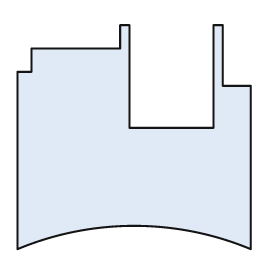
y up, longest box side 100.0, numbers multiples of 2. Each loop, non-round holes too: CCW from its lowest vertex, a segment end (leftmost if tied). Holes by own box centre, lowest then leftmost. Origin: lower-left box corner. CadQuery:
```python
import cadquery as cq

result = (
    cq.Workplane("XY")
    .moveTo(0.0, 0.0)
    .threePointArc((50.0, 10.0), (100.0, 0.0))
    .lineTo(100.0, 70.0)
    .lineTo(88.0, 70.0)
    .lineTo(88.0, 96.0)
    .lineTo(84.0, 96.0)
    .lineTo(84.0, 52.0)
    .lineTo(48.0, 52.0)
    .lineTo(48.0, 96.0)
    .lineTo(44.0, 96.0)
    .lineTo(44.0, 86.0)
    .lineTo(6.0, 86.0)
    .lineTo(6.0, 76.0)
    .lineTo(0.0, 76.0)
    .close()
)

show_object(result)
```